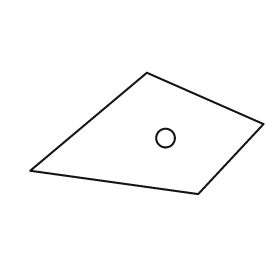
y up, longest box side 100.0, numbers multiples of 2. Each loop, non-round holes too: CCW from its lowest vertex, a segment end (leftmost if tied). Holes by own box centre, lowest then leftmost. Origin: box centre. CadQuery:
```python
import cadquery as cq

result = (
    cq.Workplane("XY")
    .moveTo(22.0, -26.0)
    .lineTo(50.0, 4.0)
    .lineTo(0.0, 26.0)
    .lineTo(-50.0, -16.0)
    .close()
    .moveTo(8.0, -2.0)
    .circle(4.0)
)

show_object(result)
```